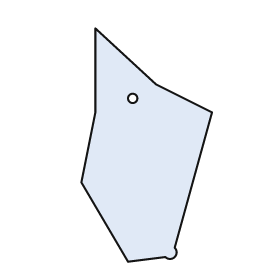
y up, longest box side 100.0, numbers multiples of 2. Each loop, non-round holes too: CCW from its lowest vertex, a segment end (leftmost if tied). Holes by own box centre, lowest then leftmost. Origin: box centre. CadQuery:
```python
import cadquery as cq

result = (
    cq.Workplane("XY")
    .moveTo(-8.0, -50.0)
    .lineTo(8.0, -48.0)
    .threePointArc((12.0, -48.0), (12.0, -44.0))
    .lineTo(28.0, 14.0)
    .lineTo(4.0, 26.0)
    .lineTo(-22.0, 50.0)
    .lineTo(-22.0, 14.0)
    .lineTo(-28.0, -16.0)
    .close()
    .moveTo(-6.0, 20.0)
    .circle(2.0)
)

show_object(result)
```